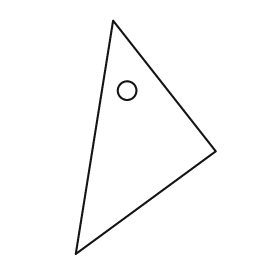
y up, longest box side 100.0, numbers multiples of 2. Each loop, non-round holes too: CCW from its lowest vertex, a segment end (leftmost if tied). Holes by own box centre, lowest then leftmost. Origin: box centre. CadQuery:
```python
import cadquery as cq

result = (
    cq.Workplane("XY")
    .moveTo(-30.0, -50.0)
    .lineTo(30.0, -6.0)
    .lineTo(-14.0, 50.0)
    .close()
    .moveTo(-8.0, 20.0)
    .circle(4.0)
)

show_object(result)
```